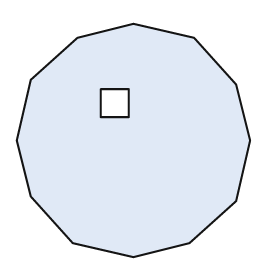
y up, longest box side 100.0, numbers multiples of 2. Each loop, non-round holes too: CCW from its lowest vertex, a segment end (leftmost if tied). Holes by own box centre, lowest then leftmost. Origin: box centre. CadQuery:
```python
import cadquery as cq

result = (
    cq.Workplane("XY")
    .moveTo(0.0, -50.0)
    .lineTo(24.0, -44.0)
    .lineTo(44.0, -26.0)
    .lineTo(50.0, 0.0)
    .lineTo(44.0, 24.0)
    .lineTo(26.0, 44.0)
    .lineTo(0.0, 50.0)
    .lineTo(-24.0, 44.0)
    .lineTo(-44.0, 26.0)
    .lineTo(-50.0, 0.0)
    .lineTo(-44.0, -24.0)
    .lineTo(-26.0, -44.0)
    .close()
    .moveTo(-14.0, 10.0)
    .lineTo(-2.0, 10.0)
    .lineTo(-2.0, 22.0)
    .lineTo(-14.0, 22.0)
    .close()
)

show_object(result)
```